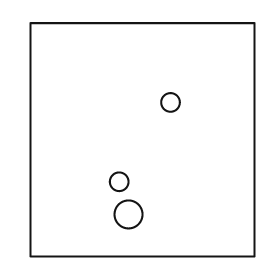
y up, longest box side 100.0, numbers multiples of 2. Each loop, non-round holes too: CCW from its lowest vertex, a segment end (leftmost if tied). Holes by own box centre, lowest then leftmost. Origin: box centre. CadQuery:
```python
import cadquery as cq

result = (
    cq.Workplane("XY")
    .moveTo(-48.0, -50.0)
    .lineTo(48.0, -50.0)
    .lineTo(48.0, 50.0)
    .lineTo(-48.0, 50.0)
    .close()
    .moveTo(-6.0, -32.0)
    .circle(6.0)
    .moveTo(-10.0, -18.0)
    .circle(4.0)
    .moveTo(12.0, 16.0)
    .circle(4.0)
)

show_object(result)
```